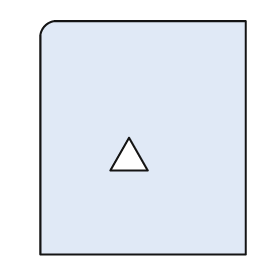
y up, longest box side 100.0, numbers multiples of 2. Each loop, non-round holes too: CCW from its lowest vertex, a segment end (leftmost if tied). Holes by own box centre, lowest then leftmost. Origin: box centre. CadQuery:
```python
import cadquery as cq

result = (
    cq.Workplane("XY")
    .moveTo(-44.0, -50.0)
    .lineTo(44.0, -50.0)
    .lineTo(44.0, 50.0)
    .lineTo(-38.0, 50.0)
    .threePointArc((-42.0, 48.0), (-44.0, 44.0))
    .close()
    .moveTo(-14.0, -14.0)
    .lineTo(2.0, -14.0)
    .lineTo(-6.0, 0.0)
    .close()
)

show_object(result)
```